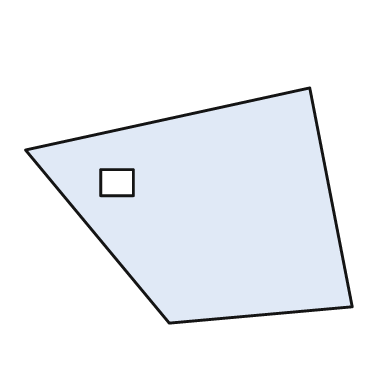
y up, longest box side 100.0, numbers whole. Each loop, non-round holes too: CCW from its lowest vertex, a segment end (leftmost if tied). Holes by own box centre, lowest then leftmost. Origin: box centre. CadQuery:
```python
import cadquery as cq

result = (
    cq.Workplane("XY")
    .moveTo(-6.0, -36.0)
    .lineTo(50.0, -31.0)
    .lineTo(37.0, 36.0)
    .lineTo(-50.0, 17.0)
    .close()
    .moveTo(-27.0, 3.0)
    .lineTo(-17.0, 3.0)
    .lineTo(-17.0, 11.0)
    .lineTo(-27.0, 11.0)
    .close()
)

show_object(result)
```